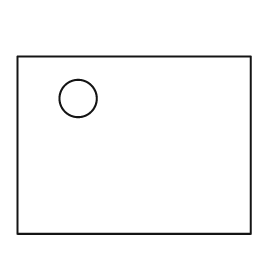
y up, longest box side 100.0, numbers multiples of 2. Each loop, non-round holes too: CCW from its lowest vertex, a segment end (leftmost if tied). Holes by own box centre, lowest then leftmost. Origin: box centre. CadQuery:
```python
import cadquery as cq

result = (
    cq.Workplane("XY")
    .moveTo(-50.0, -38.0)
    .lineTo(50.0, -38.0)
    .lineTo(50.0, 38.0)
    .lineTo(-50.0, 38.0)
    .close()
    .moveTo(-24.0, 20.0)
    .circle(8.0)
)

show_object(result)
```